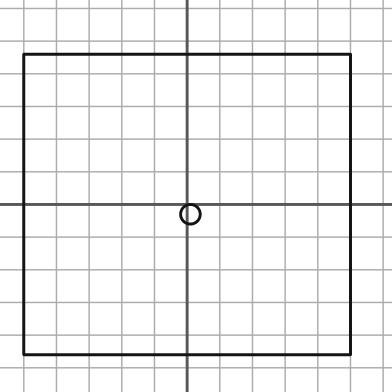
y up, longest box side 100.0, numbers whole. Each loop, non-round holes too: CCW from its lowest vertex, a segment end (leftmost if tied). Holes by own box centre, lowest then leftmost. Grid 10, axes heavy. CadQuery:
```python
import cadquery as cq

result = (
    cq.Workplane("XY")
    .moveTo(-50.0, -46.0)
    .lineTo(50.0, -46.0)
    .lineTo(50.0, 46.0)
    .lineTo(-50.0, 46.0)
    .close()
    .moveTo(1.0, -3.0)
    .circle(3.0)
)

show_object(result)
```